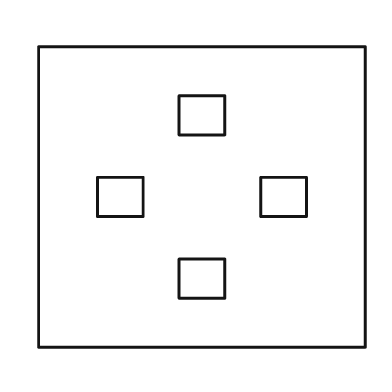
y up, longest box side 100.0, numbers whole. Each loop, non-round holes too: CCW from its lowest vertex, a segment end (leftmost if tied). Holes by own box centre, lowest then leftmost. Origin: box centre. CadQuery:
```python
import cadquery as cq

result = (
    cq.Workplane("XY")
    .moveTo(-50.0, -46.0)
    .lineTo(50.0, -46.0)
    .lineTo(50.0, 46.0)
    .lineTo(-50.0, 46.0)
    .close()
    .moveTo(-7.0, -31.0)
    .lineTo(7.0, -31.0)
    .lineTo(7.0, -19.0)
    .lineTo(-7.0, -19.0)
    .close()
    .moveTo(-32.0, -6.0)
    .lineTo(-18.0, -6.0)
    .lineTo(-18.0, 6.0)
    .lineTo(-32.0, 6.0)
    .close()
    .moveTo(18.0, -6.0)
    .lineTo(32.0, -6.0)
    .lineTo(32.0, 6.0)
    .lineTo(18.0, 6.0)
    .close()
    .moveTo(-7.0, 19.0)
    .lineTo(7.0, 19.0)
    .lineTo(7.0, 31.0)
    .lineTo(-7.0, 31.0)
    .close()
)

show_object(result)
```